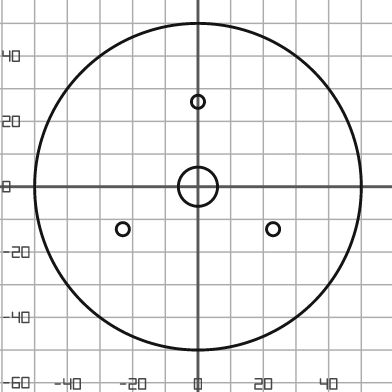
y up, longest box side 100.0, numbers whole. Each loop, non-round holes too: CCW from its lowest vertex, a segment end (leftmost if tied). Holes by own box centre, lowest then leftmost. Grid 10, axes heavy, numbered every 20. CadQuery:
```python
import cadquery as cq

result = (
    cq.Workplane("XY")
    .moveTo(0.0, 0.0)
    .circle(50.0)
    .moveTo(-23.0, -13.0)
    .circle(2.0)
    .moveTo(23.0, -13.0)
    .circle(2.0)
    .moveTo(0.0, 0.0)
    .circle(6.0)
    .moveTo(0.0, 26.0)
    .circle(2.0)
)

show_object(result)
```